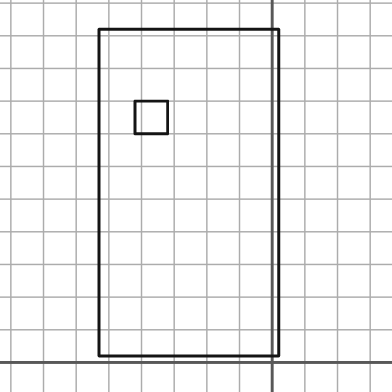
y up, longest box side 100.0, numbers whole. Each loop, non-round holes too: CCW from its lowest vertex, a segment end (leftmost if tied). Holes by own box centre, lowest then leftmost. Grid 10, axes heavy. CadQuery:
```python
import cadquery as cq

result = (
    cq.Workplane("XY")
    .moveTo(-53.0, 2.0)
    .lineTo(2.0, 2.0)
    .lineTo(2.0, 102.0)
    .lineTo(-53.0, 102.0)
    .close()
    .moveTo(-42.0, 70.0)
    .lineTo(-32.0, 70.0)
    .lineTo(-32.0, 80.0)
    .lineTo(-42.0, 80.0)
    .close()
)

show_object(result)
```